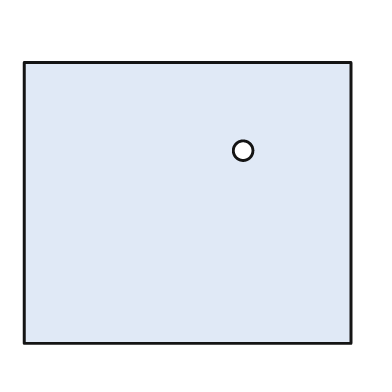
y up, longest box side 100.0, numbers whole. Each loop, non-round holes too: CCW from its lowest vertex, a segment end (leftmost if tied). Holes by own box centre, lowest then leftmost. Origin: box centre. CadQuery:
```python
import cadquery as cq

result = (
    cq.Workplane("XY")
    .moveTo(-50.0, -43.0)
    .lineTo(50.0, -43.0)
    .lineTo(50.0, 43.0)
    .lineTo(-50.0, 43.0)
    .close()
    .moveTo(17.0, 16.0)
    .circle(3.0)
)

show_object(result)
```